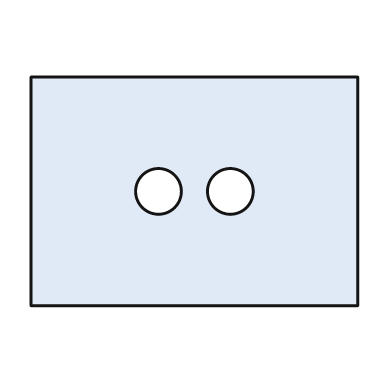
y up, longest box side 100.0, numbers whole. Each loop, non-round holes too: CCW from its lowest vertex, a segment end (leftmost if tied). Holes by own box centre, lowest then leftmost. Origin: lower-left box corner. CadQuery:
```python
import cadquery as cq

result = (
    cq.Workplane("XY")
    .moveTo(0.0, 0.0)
    .lineTo(100.0, 0.0)
    .lineTo(100.0, 70.0)
    .lineTo(0.0, 70.0)
    .close()
    .moveTo(39.0, 35.0)
    .circle(7.0)
    .moveTo(61.0, 35.0)
    .circle(7.0)
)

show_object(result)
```